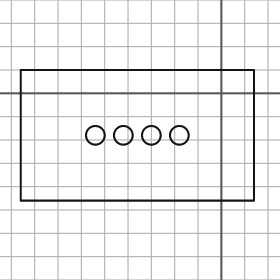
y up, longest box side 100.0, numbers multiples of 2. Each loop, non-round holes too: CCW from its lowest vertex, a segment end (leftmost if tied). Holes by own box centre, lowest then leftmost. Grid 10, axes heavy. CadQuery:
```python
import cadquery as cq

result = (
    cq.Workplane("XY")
    .moveTo(-86.0, -46.0)
    .lineTo(14.0, -46.0)
    .lineTo(14.0, 10.0)
    .lineTo(-86.0, 10.0)
    .close()
    .moveTo(-54.0, -18.0)
    .circle(4.0)
    .moveTo(-42.0, -18.0)
    .circle(4.0)
    .moveTo(-30.0, -18.0)
    .circle(4.0)
    .moveTo(-18.0, -18.0)
    .circle(4.0)
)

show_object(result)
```